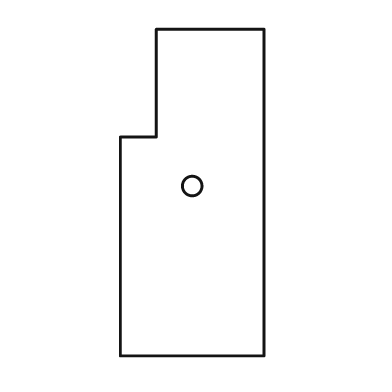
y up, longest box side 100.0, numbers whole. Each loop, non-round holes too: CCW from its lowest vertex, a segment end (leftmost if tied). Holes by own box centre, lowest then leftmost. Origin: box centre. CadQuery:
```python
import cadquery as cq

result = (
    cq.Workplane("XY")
    .moveTo(-22.0, -50.0)
    .lineTo(22.0, -50.0)
    .lineTo(22.0, 50.0)
    .lineTo(-11.0, 50.0)
    .lineTo(-11.0, 17.0)
    .lineTo(-22.0, 17.0)
    .close()
    .moveTo(0.0, 2.0)
    .circle(3.0)
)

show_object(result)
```